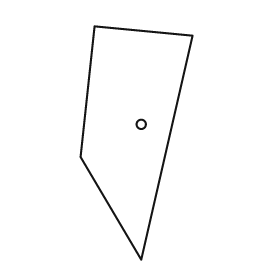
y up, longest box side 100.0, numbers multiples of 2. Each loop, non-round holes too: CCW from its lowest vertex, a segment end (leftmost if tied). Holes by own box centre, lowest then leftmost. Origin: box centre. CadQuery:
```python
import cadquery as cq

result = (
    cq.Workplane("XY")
    .moveTo(2.0, -50.0)
    .lineTo(24.0, 46.0)
    .lineTo(-18.0, 50.0)
    .lineTo(-24.0, -6.0)
    .close()
    .moveTo(2.0, 8.0)
    .circle(2.0)
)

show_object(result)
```